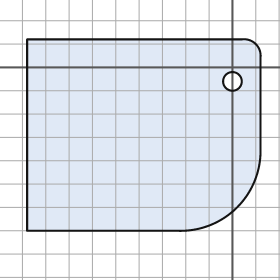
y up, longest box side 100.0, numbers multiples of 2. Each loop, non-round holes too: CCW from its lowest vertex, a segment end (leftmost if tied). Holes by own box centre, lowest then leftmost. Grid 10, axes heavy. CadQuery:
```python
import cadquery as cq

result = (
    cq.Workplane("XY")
    .moveTo(-88.0, -70.0)
    .lineTo(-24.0, -70.0)
    .threePointArc((2.0, -60.0), (12.0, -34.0))
    .lineTo(12.0, 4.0)
    .threePointArc((10.0, 10.0), (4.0, 12.0))
    .lineTo(-88.0, 12.0)
    .close()
    .moveTo(0.0, -6.0)
    .circle(4.0)
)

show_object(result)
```